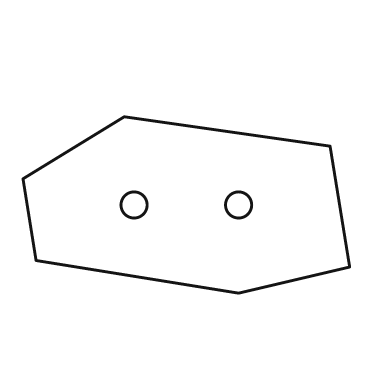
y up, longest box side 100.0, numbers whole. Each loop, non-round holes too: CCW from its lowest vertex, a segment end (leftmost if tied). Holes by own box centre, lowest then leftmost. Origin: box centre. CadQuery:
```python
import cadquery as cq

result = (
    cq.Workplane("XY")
    .moveTo(16.0, -27.0)
    .lineTo(50.0, -19.0)
    .lineTo(44.0, 18.0)
    .lineTo(-19.0, 27.0)
    .lineTo(-50.0, 8.0)
    .lineTo(-46.0, -17.0)
    .close()
    .moveTo(-16.0, 0.0)
    .circle(4.0)
    .moveTo(16.0, 0.0)
    .circle(4.0)
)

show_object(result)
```